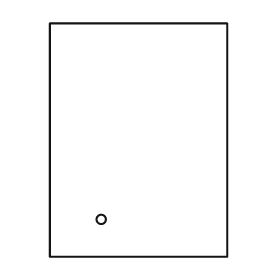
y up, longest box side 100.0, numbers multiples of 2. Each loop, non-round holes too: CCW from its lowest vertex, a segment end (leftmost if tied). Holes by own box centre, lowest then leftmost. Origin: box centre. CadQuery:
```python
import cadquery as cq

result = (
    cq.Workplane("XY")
    .moveTo(-38.0, -50.0)
    .lineTo(38.0, -50.0)
    .lineTo(38.0, 50.0)
    .lineTo(-38.0, 50.0)
    .close()
    .moveTo(-16.0, -34.0)
    .circle(2.0)
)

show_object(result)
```